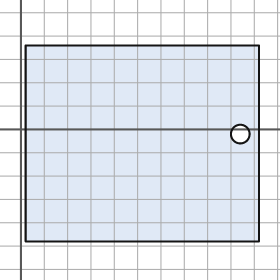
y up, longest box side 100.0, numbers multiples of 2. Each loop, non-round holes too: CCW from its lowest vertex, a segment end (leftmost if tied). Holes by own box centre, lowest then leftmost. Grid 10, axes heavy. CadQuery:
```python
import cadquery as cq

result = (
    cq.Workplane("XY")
    .moveTo(2.0, -48.0)
    .lineTo(102.0, -48.0)
    .lineTo(102.0, 36.0)
    .lineTo(2.0, 36.0)
    .close()
    .moveTo(94.0, -2.0)
    .circle(4.0)
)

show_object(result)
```